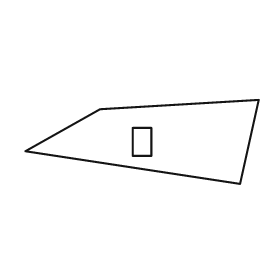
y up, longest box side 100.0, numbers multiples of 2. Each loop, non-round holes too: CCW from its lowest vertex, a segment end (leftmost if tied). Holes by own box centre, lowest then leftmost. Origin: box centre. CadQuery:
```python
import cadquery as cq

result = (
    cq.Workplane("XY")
    .moveTo(42.0, -18.0)
    .lineTo(50.0, 18.0)
    .lineTo(-18.0, 14.0)
    .lineTo(-50.0, -4.0)
    .close()
    .moveTo(-4.0, -6.0)
    .lineTo(4.0, -6.0)
    .lineTo(4.0, 6.0)
    .lineTo(-4.0, 6.0)
    .close()
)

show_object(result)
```